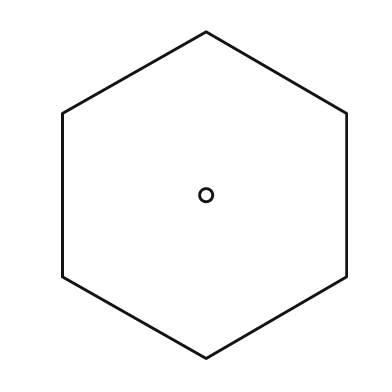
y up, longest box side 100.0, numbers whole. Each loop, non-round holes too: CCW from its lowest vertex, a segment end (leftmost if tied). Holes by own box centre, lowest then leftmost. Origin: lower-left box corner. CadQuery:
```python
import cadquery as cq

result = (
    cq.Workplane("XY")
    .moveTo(44.0, 0.0)
    .lineTo(87.0, 25.0)
    .lineTo(87.0, 75.0)
    .lineTo(44.0, 100.0)
    .lineTo(0.0, 75.0)
    .lineTo(0.0, 25.0)
    .close()
    .moveTo(44.0, 50.0)
    .circle(2.0)
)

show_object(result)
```